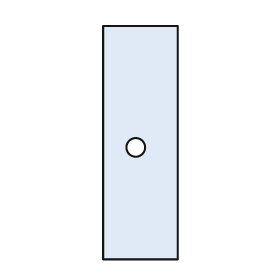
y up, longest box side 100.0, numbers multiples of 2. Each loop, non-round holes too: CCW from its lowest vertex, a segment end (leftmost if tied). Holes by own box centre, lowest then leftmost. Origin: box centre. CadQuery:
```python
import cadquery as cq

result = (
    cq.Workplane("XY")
    .moveTo(-16.0, -50.0)
    .lineTo(16.0, -50.0)
    .lineTo(16.0, 50.0)
    .lineTo(-16.0, 50.0)
    .close()
    .moveTo(-2.0, -2.0)
    .circle(4.0)
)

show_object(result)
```